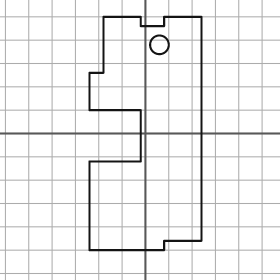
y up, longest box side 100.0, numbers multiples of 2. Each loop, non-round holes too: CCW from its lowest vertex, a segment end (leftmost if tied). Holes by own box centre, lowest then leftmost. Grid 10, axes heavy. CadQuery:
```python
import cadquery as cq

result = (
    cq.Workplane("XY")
    .moveTo(-24.0, -50.0)
    .lineTo(8.0, -50.0)
    .lineTo(8.0, -46.0)
    .lineTo(24.0, -46.0)
    .lineTo(24.0, 50.0)
    .lineTo(8.0, 50.0)
    .lineTo(8.0, 46.0)
    .lineTo(-2.0, 46.0)
    .lineTo(-2.0, 50.0)
    .lineTo(-18.0, 50.0)
    .lineTo(-18.0, 26.0)
    .lineTo(-24.0, 26.0)
    .lineTo(-24.0, 10.0)
    .lineTo(-2.0, 10.0)
    .lineTo(-2.0, -12.0)
    .lineTo(-24.0, -12.0)
    .close()
    .moveTo(6.0, 38.0)
    .circle(4.0)
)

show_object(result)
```